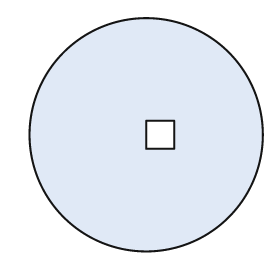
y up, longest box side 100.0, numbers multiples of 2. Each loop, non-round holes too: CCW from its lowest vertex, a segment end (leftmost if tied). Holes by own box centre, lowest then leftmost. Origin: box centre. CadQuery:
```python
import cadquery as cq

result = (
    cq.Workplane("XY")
    .moveTo(0.0, 0.0)
    .circle(50.0)
    .moveTo(0.0, -6.0)
    .lineTo(12.0, -6.0)
    .lineTo(12.0, 6.0)
    .lineTo(0.0, 6.0)
    .close()
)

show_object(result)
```